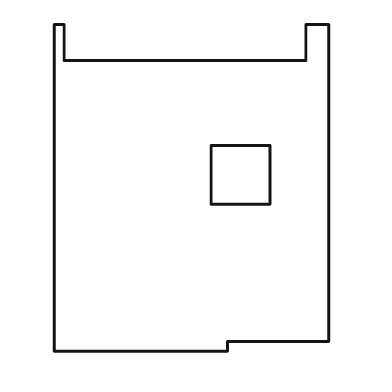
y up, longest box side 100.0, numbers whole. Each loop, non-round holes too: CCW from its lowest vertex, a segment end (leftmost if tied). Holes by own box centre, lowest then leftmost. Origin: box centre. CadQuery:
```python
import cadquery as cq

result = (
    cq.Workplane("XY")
    .moveTo(-42.0, -50.0)
    .lineTo(11.0, -50.0)
    .lineTo(11.0, -47.0)
    .lineTo(42.0, -47.0)
    .lineTo(42.0, 50.0)
    .lineTo(35.0, 50.0)
    .lineTo(35.0, 39.0)
    .lineTo(-39.0, 39.0)
    .lineTo(-39.0, 50.0)
    .lineTo(-42.0, 50.0)
    .close()
    .moveTo(6.0, -5.0)
    .lineTo(24.0, -5.0)
    .lineTo(24.0, 13.0)
    .lineTo(6.0, 13.0)
    .close()
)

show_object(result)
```